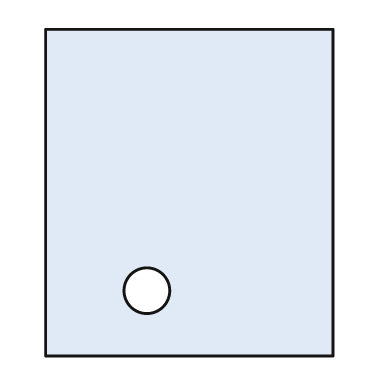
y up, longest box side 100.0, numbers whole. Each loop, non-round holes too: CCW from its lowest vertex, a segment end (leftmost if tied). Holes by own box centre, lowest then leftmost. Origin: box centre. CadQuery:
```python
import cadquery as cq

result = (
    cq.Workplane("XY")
    .moveTo(-44.0, -50.0)
    .lineTo(44.0, -50.0)
    .lineTo(44.0, 50.0)
    .lineTo(-44.0, 50.0)
    .close()
    .moveTo(-13.0, -30.0)
    .circle(7.0)
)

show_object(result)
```